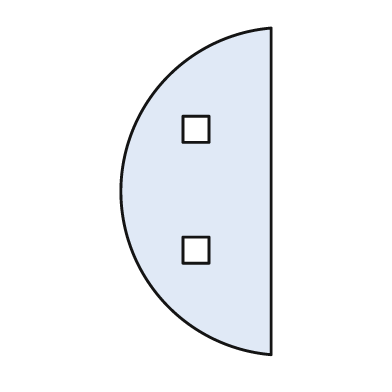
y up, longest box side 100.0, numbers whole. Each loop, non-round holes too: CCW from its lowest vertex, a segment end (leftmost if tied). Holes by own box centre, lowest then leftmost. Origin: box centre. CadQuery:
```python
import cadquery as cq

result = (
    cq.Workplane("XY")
    .moveTo(23.0, -50.0)
    .lineTo(23.0, 50.0)
    .threePointArc((-23.0, 0.0), (23.0, -50.0))
    .close()
    .moveTo(-4.0, -22.0)
    .lineTo(4.0, -22.0)
    .lineTo(4.0, -14.0)
    .lineTo(-4.0, -14.0)
    .close()
    .moveTo(-4.0, 15.0)
    .lineTo(4.0, 15.0)
    .lineTo(4.0, 23.0)
    .lineTo(-4.0, 23.0)
    .close()
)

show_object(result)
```